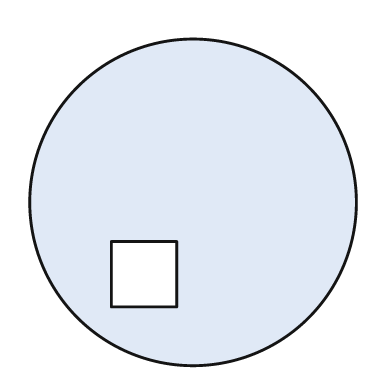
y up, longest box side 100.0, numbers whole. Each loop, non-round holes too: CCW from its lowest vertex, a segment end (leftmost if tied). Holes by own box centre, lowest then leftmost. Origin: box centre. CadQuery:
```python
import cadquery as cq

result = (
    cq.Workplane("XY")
    .moveTo(0.0, 0.0)
    .circle(50.0)
    .moveTo(-25.0, -32.0)
    .lineTo(-5.0, -32.0)
    .lineTo(-5.0, -12.0)
    .lineTo(-25.0, -12.0)
    .close()
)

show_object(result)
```